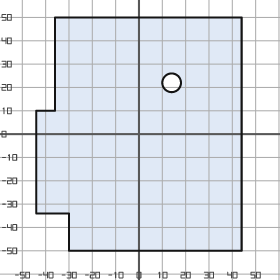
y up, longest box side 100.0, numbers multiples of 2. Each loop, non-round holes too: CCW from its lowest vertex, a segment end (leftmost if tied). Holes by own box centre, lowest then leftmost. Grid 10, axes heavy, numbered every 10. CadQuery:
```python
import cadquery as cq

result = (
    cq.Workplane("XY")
    .moveTo(-30.0, -50.0)
    .lineTo(44.0, -50.0)
    .lineTo(44.0, 50.0)
    .lineTo(-36.0, 50.0)
    .lineTo(-36.0, 10.0)
    .lineTo(-44.0, 10.0)
    .lineTo(-44.0, -34.0)
    .lineTo(-30.0, -34.0)
    .close()
    .moveTo(14.0, 22.0)
    .circle(4.0)
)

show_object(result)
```